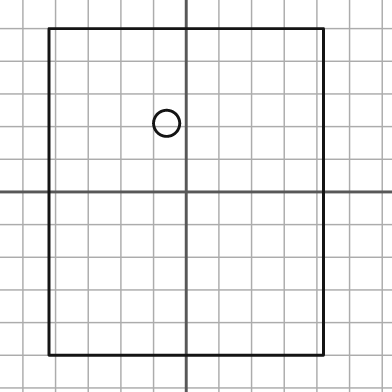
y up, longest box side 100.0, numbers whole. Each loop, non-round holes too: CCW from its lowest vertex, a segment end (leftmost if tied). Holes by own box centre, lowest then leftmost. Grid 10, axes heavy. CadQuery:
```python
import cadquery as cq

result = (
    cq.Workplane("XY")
    .moveTo(-42.0, -50.0)
    .lineTo(42.0, -50.0)
    .lineTo(42.0, 50.0)
    .lineTo(-42.0, 50.0)
    .close()
    .moveTo(-6.0, 21.0)
    .circle(4.0)
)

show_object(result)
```